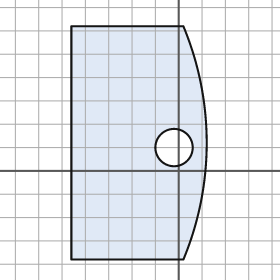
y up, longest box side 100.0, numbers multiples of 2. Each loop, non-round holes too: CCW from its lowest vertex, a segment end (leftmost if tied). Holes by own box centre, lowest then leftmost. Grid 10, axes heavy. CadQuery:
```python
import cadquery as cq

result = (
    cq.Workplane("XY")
    .moveTo(-46.0, -38.0)
    .lineTo(2.0, -38.0)
    .threePointArc((12.0, 12.0), (2.0, 62.0))
    .lineTo(-46.0, 62.0)
    .close()
    .moveTo(-2.0, 10.0)
    .circle(8.0)
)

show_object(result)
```